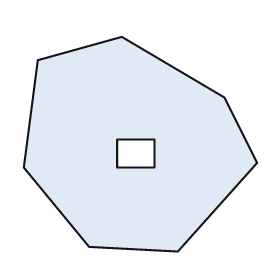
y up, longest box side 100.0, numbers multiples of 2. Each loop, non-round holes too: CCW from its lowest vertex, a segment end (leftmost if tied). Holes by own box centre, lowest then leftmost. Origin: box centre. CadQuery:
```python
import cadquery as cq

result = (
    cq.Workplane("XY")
    .moveTo(16.0, -46.0)
    .lineTo(50.0, -8.0)
    .lineTo(36.0, 20.0)
    .lineTo(-8.0, 46.0)
    .lineTo(-44.0, 36.0)
    .lineTo(-50.0, -10.0)
    .lineTo(-22.0, -44.0)
    .close()
    .moveTo(-10.0, -10.0)
    .lineTo(6.0, -10.0)
    .lineTo(6.0, 2.0)
    .lineTo(-10.0, 2.0)
    .close()
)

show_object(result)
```